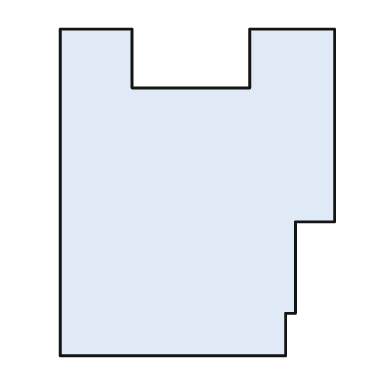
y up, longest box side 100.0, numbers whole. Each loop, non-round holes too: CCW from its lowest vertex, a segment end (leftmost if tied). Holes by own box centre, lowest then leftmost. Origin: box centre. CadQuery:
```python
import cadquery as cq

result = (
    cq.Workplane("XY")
    .moveTo(-42.0, -50.0)
    .lineTo(27.0, -50.0)
    .lineTo(27.0, -37.0)
    .lineTo(30.0, -37.0)
    .lineTo(30.0, -9.0)
    .lineTo(42.0, -9.0)
    .lineTo(42.0, 50.0)
    .lineTo(16.0, 50.0)
    .lineTo(16.0, 32.0)
    .lineTo(-20.0, 32.0)
    .lineTo(-20.0, 50.0)
    .lineTo(-42.0, 50.0)
    .close()
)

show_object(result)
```